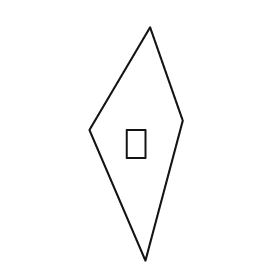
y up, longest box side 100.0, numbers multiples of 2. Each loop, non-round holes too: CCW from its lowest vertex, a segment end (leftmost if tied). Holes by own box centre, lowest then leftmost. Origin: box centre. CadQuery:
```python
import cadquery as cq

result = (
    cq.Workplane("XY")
    .moveTo(4.0, -50.0)
    .lineTo(20.0, 10.0)
    .lineTo(6.0, 50.0)
    .lineTo(-20.0, 6.0)
    .close()
    .moveTo(-4.0, -6.0)
    .lineTo(4.0, -6.0)
    .lineTo(4.0, 6.0)
    .lineTo(-4.0, 6.0)
    .close()
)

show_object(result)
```